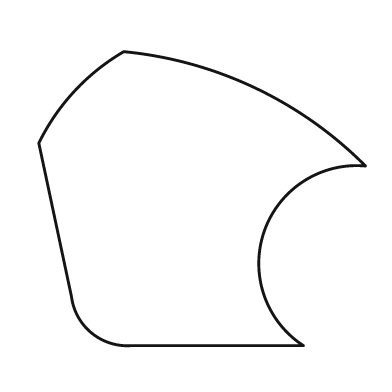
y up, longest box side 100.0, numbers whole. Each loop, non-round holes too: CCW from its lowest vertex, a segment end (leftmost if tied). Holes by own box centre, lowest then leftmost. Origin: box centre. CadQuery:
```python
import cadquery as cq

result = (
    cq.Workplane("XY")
    .moveTo(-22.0, -45.0)
    .lineTo(31.0, -45.0)
    .threePointArc((19.0, -10.0), (50.0, 10.0))
    .threePointArc((16.0, 34.0), (-24.0, 45.0))
    .threePointArc((-39.0, 33.0), (-50.0, 17.0))
    .lineTo(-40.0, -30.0)
    .threePointArc((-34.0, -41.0), (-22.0, -45.0))
    .close()
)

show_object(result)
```